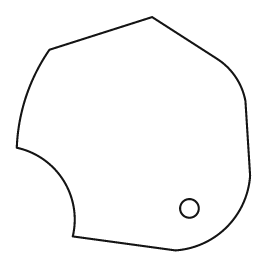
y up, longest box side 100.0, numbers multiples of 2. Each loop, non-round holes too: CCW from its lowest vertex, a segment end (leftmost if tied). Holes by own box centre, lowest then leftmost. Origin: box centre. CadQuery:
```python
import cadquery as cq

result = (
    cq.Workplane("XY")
    .moveTo(18.0, -50.0)
    .threePointArc((40.0, -40.0), (50.0, -18.0))
    .lineTo(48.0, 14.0)
    .threePointArc((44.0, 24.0), (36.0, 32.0))
    .lineTo(8.0, 50.0)
    .lineTo(-36.0, 36.0)
    .threePointArc((-46.0, 16.0), (-50.0, -6.0))
    .threePointArc((-30.0, -20.0), (-26.0, -44.0))
    .close()
    .moveTo(24.0, -32.0)
    .circle(4.0)
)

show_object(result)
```